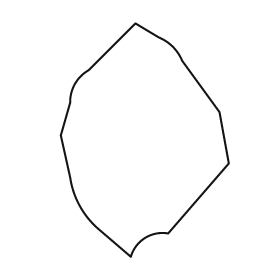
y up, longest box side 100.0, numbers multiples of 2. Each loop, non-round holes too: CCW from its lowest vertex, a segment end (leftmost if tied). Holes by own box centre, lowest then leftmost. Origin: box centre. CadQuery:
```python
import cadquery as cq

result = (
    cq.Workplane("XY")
    .moveTo(-6.0, -50.0)
    .threePointArc((0.0, -42.0), (10.0, -40.0))
    .lineTo(36.0, -10.0)
    .lineTo(32.0, 12.0)
    .lineTo(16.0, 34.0)
    .threePointArc((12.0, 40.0), (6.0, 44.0))
    .lineTo(-4.0, 50.0)
    .lineTo(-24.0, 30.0)
    .threePointArc((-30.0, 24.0), (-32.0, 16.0))
    .lineTo(-36.0, 2.0)
    .lineTo(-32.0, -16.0)
    .threePointArc((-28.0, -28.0), (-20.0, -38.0))
    .close()
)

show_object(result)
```